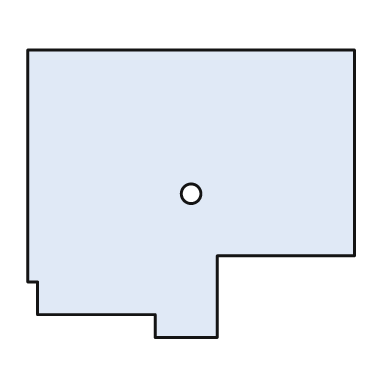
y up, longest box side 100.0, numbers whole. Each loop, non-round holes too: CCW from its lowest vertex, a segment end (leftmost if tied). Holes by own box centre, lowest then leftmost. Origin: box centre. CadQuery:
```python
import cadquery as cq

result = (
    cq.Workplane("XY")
    .moveTo(-11.0, -44.0)
    .lineTo(8.0, -44.0)
    .lineTo(8.0, -19.0)
    .lineTo(50.0, -19.0)
    .lineTo(50.0, 44.0)
    .lineTo(-50.0, 44.0)
    .lineTo(-50.0, -27.0)
    .lineTo(-47.0, -27.0)
    .lineTo(-47.0, -37.0)
    .lineTo(-11.0, -37.0)
    .close()
    .moveTo(0.0, 0.0)
    .circle(3.0)
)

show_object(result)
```